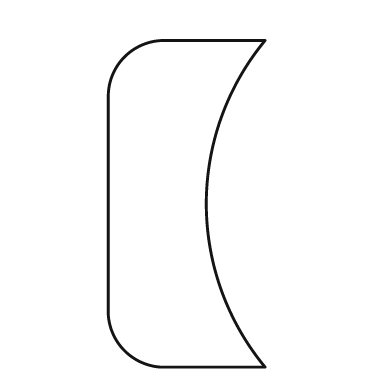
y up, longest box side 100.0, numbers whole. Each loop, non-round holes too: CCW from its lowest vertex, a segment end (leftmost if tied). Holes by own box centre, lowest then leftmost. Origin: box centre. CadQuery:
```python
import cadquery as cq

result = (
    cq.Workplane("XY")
    .moveTo(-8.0, -50.0)
    .lineTo(24.0, -50.0)
    .threePointArc((6.0, 0.0), (24.0, 50.0))
    .lineTo(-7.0, 50.0)
    .threePointArc((-19.0, 45.0), (-24.0, 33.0))
    .lineTo(-24.0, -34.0)
    .threePointArc((-19.0, -45.0), (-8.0, -50.0))
    .close()
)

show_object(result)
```